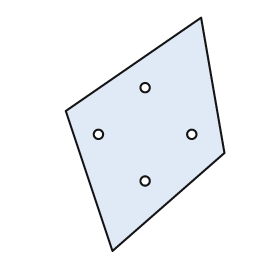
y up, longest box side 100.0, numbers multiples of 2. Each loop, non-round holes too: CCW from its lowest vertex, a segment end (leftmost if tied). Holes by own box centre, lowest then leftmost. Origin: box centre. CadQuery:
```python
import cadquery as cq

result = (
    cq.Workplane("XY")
    .moveTo(-14.0, -50.0)
    .lineTo(34.0, -8.0)
    .lineTo(24.0, 50.0)
    .lineTo(-34.0, 10.0)
    .close()
    .moveTo(0.0, -20.0)
    .circle(2.0)
    .moveTo(-20.0, 0.0)
    .circle(2.0)
    .moveTo(20.0, 0.0)
    .circle(2.0)
    .moveTo(0.0, 20.0)
    .circle(2.0)
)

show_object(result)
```